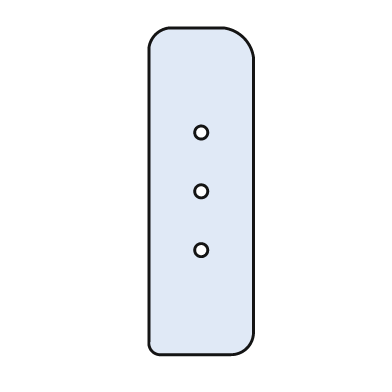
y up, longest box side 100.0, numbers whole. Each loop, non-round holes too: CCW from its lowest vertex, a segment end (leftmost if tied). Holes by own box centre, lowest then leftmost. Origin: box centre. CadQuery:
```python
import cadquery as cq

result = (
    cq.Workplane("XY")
    .moveTo(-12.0, -50.0)
    .lineTo(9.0, -50.0)
    .threePointArc((14.0, -48.0), (16.0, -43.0))
    .lineTo(16.0, 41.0)
    .threePointArc((13.0, 47.0), (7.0, 50.0))
    .lineTo(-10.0, 50.0)
    .threePointArc((-14.0, 48.0), (-16.0, 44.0))
    .lineTo(-16.0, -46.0)
    .threePointArc((-15.0, -49.0), (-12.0, -50.0))
    .close()
    .moveTo(0.0, -18.0)
    .circle(2.0)
    .moveTo(0.0, 0.0)
    .circle(2.0)
    .moveTo(0.0, 18.0)
    .circle(2.0)
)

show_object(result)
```